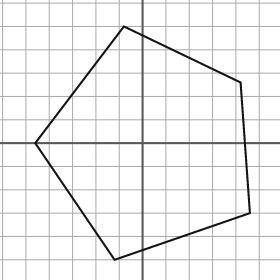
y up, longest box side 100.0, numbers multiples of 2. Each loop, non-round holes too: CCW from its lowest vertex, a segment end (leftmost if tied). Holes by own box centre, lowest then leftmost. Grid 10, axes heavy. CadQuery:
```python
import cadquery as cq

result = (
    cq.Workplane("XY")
    .moveTo(-12.0, -50.0)
    .lineTo(46.0, -30.0)
    .lineTo(42.0, 26.0)
    .lineTo(-8.0, 50.0)
    .lineTo(-46.0, 0.0)
    .close()
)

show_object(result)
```